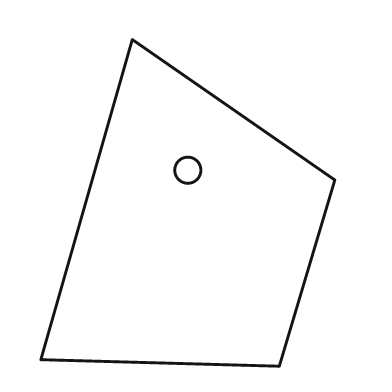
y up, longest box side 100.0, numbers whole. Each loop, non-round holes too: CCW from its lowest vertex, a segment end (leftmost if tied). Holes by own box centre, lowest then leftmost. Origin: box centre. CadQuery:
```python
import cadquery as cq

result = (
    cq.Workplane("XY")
    .moveTo(28.0, -50.0)
    .lineTo(45.0, 7.0)
    .lineTo(-17.0, 50.0)
    .lineTo(-45.0, -48.0)
    .close()
    .moveTo(0.0, 10.0)
    .circle(4.0)
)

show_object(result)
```